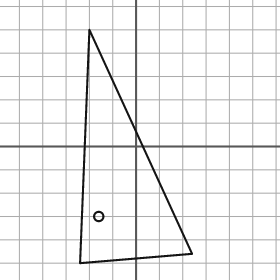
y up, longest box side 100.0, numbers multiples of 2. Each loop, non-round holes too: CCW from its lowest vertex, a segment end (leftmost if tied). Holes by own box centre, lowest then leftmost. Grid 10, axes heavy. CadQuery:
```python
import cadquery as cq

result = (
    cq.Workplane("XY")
    .moveTo(-24.0, -50.0)
    .lineTo(24.0, -46.0)
    .lineTo(-20.0, 50.0)
    .close()
    .moveTo(-16.0, -30.0)
    .circle(2.0)
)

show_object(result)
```